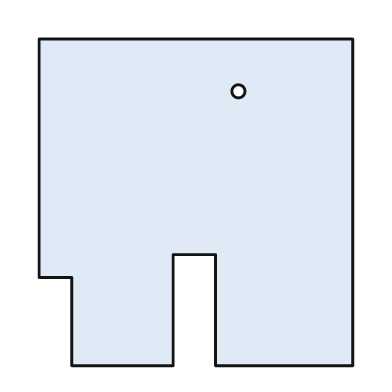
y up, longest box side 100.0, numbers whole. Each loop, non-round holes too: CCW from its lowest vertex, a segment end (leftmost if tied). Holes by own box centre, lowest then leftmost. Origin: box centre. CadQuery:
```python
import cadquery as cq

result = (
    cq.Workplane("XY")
    .moveTo(-38.0, -50.0)
    .lineTo(-7.0, -50.0)
    .lineTo(-7.0, -16.0)
    .lineTo(6.0, -16.0)
    .lineTo(6.0, -50.0)
    .lineTo(48.0, -50.0)
    .lineTo(48.0, 50.0)
    .lineTo(-48.0, 50.0)
    .lineTo(-48.0, -23.0)
    .lineTo(-38.0, -23.0)
    .close()
    .moveTo(13.0, 34.0)
    .circle(2.0)
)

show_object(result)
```